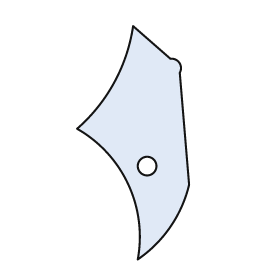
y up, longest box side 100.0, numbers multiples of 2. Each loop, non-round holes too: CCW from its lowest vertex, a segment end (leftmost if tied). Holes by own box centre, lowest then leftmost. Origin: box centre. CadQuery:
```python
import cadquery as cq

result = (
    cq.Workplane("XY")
    .moveTo(2.0, -50.0)
    .threePointArc((16.0, -36.0), (24.0, -18.0))
    .lineTo(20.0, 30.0)
    .threePointArc((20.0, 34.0), (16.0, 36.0))
    .lineTo(0.0, 50.0)
    .threePointArc((-8.0, 26.0), (-24.0, 6.0))
    .threePointArc((-2.0, -18.0), (2.0, -50.0))
    .close()
    .moveTo(6.0, -10.0)
    .circle(4.0)
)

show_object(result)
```